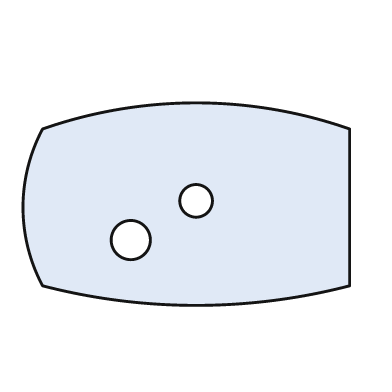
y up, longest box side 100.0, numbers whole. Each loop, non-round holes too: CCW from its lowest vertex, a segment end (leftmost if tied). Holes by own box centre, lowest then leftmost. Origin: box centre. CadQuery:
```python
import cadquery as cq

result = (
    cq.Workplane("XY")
    .moveTo(-44.0, -25.0)
    .threePointArc((3.0, -31.0), (50.0, -25.0))
    .lineTo(50.0, 23.0)
    .threePointArc((3.0, 31.0), (-44.0, 23.0))
    .threePointArc((-50.0, -1.0), (-44.0, -25.0))
    .close()
    .moveTo(-17.0, -11.0)
    .circle(6.0)
    .moveTo(3.0, 1.0)
    .circle(5.0)
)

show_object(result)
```